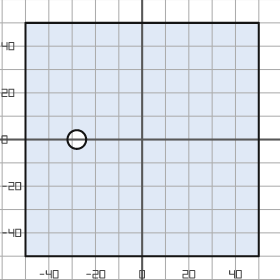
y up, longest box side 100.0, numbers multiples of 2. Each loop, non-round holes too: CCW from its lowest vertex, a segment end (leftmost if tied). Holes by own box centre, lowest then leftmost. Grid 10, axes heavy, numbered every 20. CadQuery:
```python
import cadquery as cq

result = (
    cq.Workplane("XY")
    .moveTo(-50.0, -50.0)
    .lineTo(50.0, -50.0)
    .lineTo(50.0, 50.0)
    .lineTo(-50.0, 50.0)
    .close()
    .moveTo(-28.0, 0.0)
    .circle(4.0)
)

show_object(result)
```